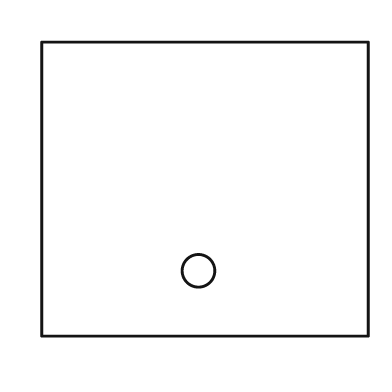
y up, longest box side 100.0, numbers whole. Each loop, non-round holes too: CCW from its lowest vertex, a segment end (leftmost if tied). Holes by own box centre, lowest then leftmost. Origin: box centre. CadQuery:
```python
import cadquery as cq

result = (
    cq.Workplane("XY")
    .moveTo(-50.0, -45.0)
    .lineTo(50.0, -45.0)
    .lineTo(50.0, 45.0)
    .lineTo(-50.0, 45.0)
    .close()
    .moveTo(-2.0, -25.0)
    .circle(5.0)
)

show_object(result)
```